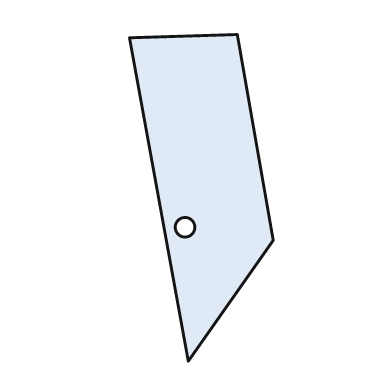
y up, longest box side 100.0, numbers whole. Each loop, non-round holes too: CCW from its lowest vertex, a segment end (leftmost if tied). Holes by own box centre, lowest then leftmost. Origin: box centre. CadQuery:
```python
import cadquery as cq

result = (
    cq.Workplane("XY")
    .moveTo(-4.0, -50.0)
    .lineTo(22.0, -13.0)
    .lineTo(11.0, 50.0)
    .lineTo(-22.0, 49.0)
    .close()
    .moveTo(-5.0, -9.0)
    .circle(3.0)
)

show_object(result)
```